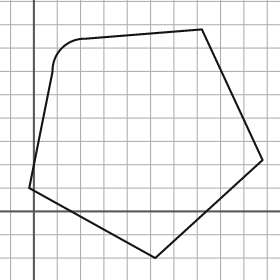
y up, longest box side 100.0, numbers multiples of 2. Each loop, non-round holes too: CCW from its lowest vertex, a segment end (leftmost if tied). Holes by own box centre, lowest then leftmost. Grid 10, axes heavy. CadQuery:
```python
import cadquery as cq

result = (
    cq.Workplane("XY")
    .moveTo(52.0, -20.0)
    .lineTo(98.0, 22.0)
    .lineTo(72.0, 78.0)
    .lineTo(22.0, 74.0)
    .threePointArc((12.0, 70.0), (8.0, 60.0))
    .lineTo(-2.0, 10.0)
    .close()
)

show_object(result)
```